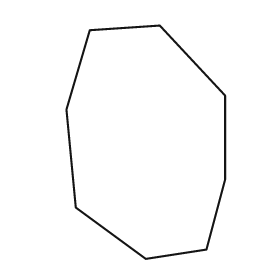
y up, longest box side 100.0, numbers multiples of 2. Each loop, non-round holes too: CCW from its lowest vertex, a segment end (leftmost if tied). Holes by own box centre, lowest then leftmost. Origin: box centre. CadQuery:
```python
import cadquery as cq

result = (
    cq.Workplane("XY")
    .moveTo(0.0, -50.0)
    .lineTo(26.0, -46.0)
    .lineTo(34.0, -16.0)
    .lineTo(34.0, 20.0)
    .lineTo(6.0, 50.0)
    .lineTo(-24.0, 48.0)
    .lineTo(-34.0, 14.0)
    .lineTo(-30.0, -28.0)
    .close()
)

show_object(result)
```